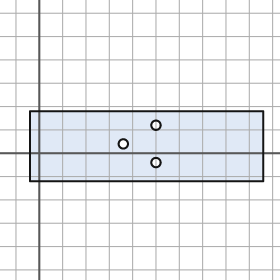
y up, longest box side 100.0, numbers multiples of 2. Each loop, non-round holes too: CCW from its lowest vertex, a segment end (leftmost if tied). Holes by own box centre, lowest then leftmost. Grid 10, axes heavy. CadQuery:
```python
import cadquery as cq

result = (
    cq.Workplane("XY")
    .moveTo(-4.0, -12.0)
    .lineTo(96.0, -12.0)
    .lineTo(96.0, 18.0)
    .lineTo(-4.0, 18.0)
    .close()
    .moveTo(50.0, -4.0)
    .circle(2.0)
    .moveTo(36.0, 4.0)
    .circle(2.0)
    .moveTo(50.0, 12.0)
    .circle(2.0)
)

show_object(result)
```